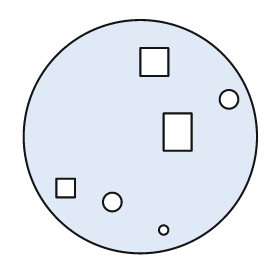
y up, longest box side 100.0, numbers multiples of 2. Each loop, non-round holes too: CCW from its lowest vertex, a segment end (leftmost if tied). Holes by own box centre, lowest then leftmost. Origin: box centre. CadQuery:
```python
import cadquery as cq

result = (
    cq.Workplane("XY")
    .moveTo(0.0, 0.0)
    .circle(50.0)
    .moveTo(10.0, -40.0)
    .circle(2.0)
    .moveTo(-12.0, -28.0)
    .circle(4.0)
    .moveTo(-36.0, -26.0)
    .lineTo(-28.0, -26.0)
    .lineTo(-28.0, -18.0)
    .lineTo(-36.0, -18.0)
    .close()
    .moveTo(10.0, -6.0)
    .lineTo(22.0, -6.0)
    .lineTo(22.0, 10.0)
    .lineTo(10.0, 10.0)
    .close()
    .moveTo(38.0, 16.0)
    .circle(4.0)
    .moveTo(0.0, 26.0)
    .lineTo(12.0, 26.0)
    .lineTo(12.0, 38.0)
    .lineTo(0.0, 38.0)
    .close()
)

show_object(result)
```